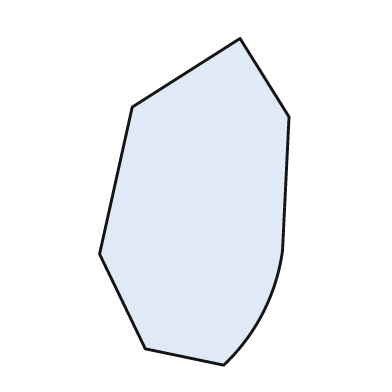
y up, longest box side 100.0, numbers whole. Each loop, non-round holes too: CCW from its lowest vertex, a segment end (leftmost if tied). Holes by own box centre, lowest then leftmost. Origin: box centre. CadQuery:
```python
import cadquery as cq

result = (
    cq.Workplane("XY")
    .moveTo(9.0, -50.0)
    .threePointArc((21.0, -34.0), (27.0, -15.0))
    .lineTo(29.0, 26.0)
    .lineTo(14.0, 50.0)
    .lineTo(-19.0, 29.0)
    .lineTo(-29.0, -16.0)
    .lineTo(-15.0, -45.0)
    .close()
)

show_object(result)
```